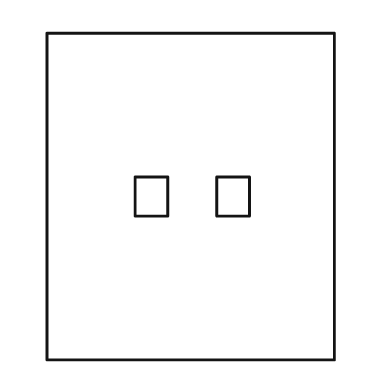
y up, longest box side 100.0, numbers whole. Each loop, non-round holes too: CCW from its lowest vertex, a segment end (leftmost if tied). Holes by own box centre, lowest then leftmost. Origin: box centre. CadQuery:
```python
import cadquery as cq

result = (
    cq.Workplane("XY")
    .moveTo(-44.0, -50.0)
    .lineTo(44.0, -50.0)
    .lineTo(44.0, 50.0)
    .lineTo(-44.0, 50.0)
    .close()
    .moveTo(-17.0, -6.0)
    .lineTo(-7.0, -6.0)
    .lineTo(-7.0, 6.0)
    .lineTo(-17.0, 6.0)
    .close()
    .moveTo(8.0, -6.0)
    .lineTo(18.0, -6.0)
    .lineTo(18.0, 6.0)
    .lineTo(8.0, 6.0)
    .close()
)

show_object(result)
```